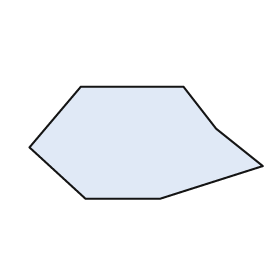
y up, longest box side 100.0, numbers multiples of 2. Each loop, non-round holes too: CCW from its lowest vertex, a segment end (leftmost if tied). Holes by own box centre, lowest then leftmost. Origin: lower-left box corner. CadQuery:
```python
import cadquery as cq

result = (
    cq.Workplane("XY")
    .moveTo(24.0, 0.0)
    .lineTo(56.0, 0.0)
    .lineTo(100.0, 14.0)
    .lineTo(80.0, 30.0)
    .lineTo(66.0, 48.0)
    .lineTo(22.0, 48.0)
    .lineTo(0.0, 22.0)
    .close()
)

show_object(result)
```